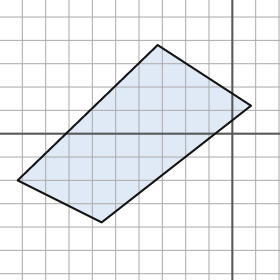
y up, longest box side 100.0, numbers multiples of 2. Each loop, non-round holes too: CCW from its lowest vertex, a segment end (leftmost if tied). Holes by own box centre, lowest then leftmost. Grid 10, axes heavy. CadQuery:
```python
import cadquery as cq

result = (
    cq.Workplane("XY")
    .moveTo(-56.0, -38.0)
    .lineTo(8.0, 12.0)
    .lineTo(-32.0, 38.0)
    .lineTo(-92.0, -20.0)
    .close()
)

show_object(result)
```